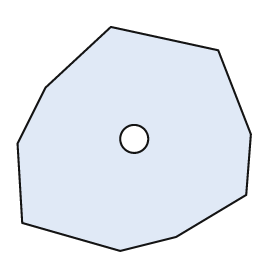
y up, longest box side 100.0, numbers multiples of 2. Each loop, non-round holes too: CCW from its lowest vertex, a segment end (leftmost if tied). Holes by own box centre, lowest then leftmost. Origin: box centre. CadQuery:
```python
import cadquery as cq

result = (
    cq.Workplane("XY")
    .moveTo(-6.0, -48.0)
    .lineTo(18.0, -42.0)
    .lineTo(48.0, -24.0)
    .lineTo(50.0, 2.0)
    .lineTo(36.0, 38.0)
    .lineTo(-10.0, 48.0)
    .lineTo(-38.0, 22.0)
    .lineTo(-50.0, -2.0)
    .lineTo(-48.0, -36.0)
    .close()
    .moveTo(0.0, 0.0)
    .circle(6.0)
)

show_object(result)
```